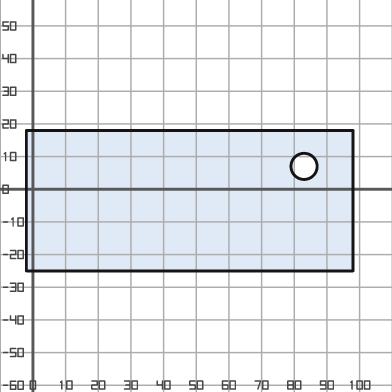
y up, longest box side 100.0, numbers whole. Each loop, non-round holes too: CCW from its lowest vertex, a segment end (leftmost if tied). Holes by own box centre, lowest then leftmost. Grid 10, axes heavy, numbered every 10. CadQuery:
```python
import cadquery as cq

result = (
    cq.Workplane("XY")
    .moveTo(-2.0, -25.0)
    .lineTo(98.0, -25.0)
    .lineTo(98.0, 18.0)
    .lineTo(-2.0, 18.0)
    .close()
    .moveTo(83.0, 7.0)
    .circle(4.0)
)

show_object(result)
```